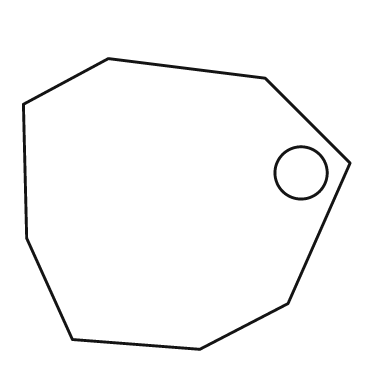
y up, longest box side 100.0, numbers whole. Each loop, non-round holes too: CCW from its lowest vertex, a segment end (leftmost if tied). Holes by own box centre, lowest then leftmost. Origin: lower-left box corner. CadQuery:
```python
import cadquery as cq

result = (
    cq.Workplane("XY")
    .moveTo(54.0, 0.0)
    .lineTo(81.0, 14.0)
    .lineTo(100.0, 57.0)
    .lineTo(74.0, 83.0)
    .lineTo(26.0, 89.0)
    .lineTo(0.0, 75.0)
    .lineTo(1.0, 34.0)
    .lineTo(15.0, 3.0)
    .close()
    .moveTo(85.0, 54.0)
    .circle(8.0)
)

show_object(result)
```